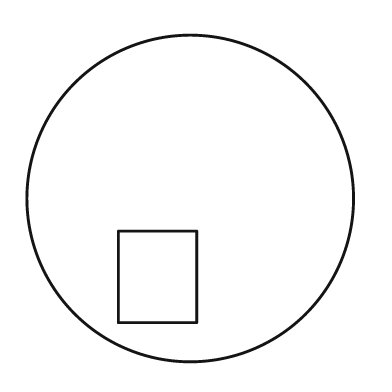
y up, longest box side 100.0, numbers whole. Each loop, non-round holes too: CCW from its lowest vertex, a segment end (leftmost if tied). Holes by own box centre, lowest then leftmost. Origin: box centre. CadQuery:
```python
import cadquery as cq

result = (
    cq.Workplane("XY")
    .moveTo(0.0, 0.0)
    .circle(50.0)
    .moveTo(-22.0, -38.0)
    .lineTo(2.0, -38.0)
    .lineTo(2.0, -10.0)
    .lineTo(-22.0, -10.0)
    .close()
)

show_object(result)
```